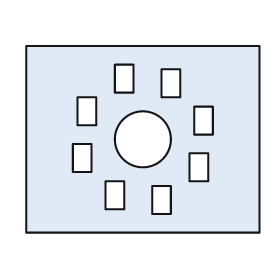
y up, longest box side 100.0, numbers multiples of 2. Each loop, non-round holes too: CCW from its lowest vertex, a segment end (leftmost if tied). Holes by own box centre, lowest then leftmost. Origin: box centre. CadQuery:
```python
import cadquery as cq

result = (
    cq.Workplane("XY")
    .moveTo(-50.0, -40.0)
    .lineTo(50.0, -40.0)
    .lineTo(50.0, 40.0)
    .lineTo(-50.0, 40.0)
    .close()
    .moveTo(4.0, -32.0)
    .lineTo(12.0, -32.0)
    .lineTo(12.0, -20.0)
    .lineTo(4.0, -20.0)
    .close()
    .moveTo(-16.0, -30.0)
    .lineTo(-8.0, -30.0)
    .lineTo(-8.0, -18.0)
    .lineTo(-16.0, -18.0)
    .close()
    .moveTo(20.0, -18.0)
    .lineTo(28.0, -18.0)
    .lineTo(28.0, -6.0)
    .lineTo(20.0, -6.0)
    .close()
    .moveTo(-30.0, -14.0)
    .lineTo(-22.0, -14.0)
    .lineTo(-22.0, -2.0)
    .lineTo(-30.0, -2.0)
    .close()
    .moveTo(0.0, 0.0)
    .circle(12.0)
    .moveTo(22.0, 2.0)
    .lineTo(30.0, 2.0)
    .lineTo(30.0, 14.0)
    .lineTo(22.0, 14.0)
    .close()
    .moveTo(-28.0, 6.0)
    .lineTo(-20.0, 6.0)
    .lineTo(-20.0, 18.0)
    .lineTo(-28.0, 18.0)
    .close()
    .moveTo(8.0, 18.0)
    .lineTo(16.0, 18.0)
    .lineTo(16.0, 30.0)
    .lineTo(8.0, 30.0)
    .close()
    .moveTo(-12.0, 20.0)
    .lineTo(-4.0, 20.0)
    .lineTo(-4.0, 32.0)
    .lineTo(-12.0, 32.0)
    .close()
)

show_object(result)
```